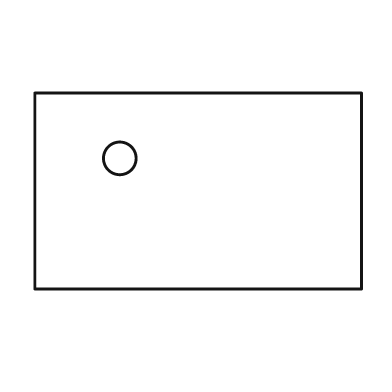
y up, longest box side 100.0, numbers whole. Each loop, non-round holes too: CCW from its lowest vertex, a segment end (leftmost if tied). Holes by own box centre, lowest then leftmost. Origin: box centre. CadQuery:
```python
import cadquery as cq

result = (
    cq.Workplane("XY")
    .moveTo(-50.0, -30.0)
    .lineTo(50.0, -30.0)
    .lineTo(50.0, 30.0)
    .lineTo(-50.0, 30.0)
    .close()
    .moveTo(-24.0, 10.0)
    .circle(5.0)
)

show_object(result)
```